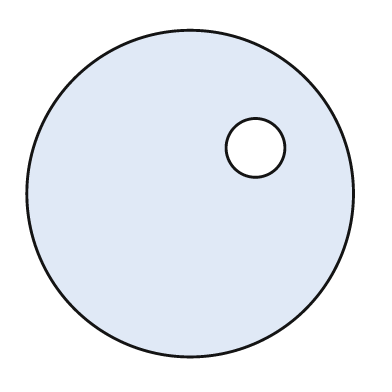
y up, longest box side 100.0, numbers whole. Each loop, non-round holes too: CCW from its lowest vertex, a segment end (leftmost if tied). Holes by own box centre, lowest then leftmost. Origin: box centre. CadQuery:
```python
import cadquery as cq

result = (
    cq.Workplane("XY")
    .moveTo(0.0, 0.0)
    .circle(50.0)
    .moveTo(20.0, 14.0)
    .circle(9.0)
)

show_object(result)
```